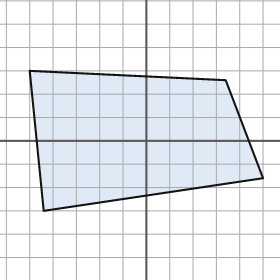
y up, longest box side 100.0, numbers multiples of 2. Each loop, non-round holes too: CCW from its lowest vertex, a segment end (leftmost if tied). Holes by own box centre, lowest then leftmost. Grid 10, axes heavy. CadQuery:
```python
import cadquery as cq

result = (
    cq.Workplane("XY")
    .moveTo(-44.0, -30.0)
    .lineTo(50.0, -16.0)
    .lineTo(34.0, 26.0)
    .lineTo(-50.0, 30.0)
    .close()
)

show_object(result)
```